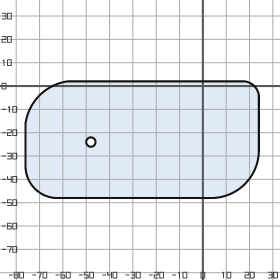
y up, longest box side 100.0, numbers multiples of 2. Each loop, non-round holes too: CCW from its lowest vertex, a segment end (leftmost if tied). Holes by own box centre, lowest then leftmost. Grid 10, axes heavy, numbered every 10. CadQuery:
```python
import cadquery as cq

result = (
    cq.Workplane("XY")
    .moveTo(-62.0, -48.0)
    .lineTo(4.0, -48.0)
    .threePointArc((18.0, -42.0), (24.0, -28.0))
    .lineTo(24.0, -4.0)
    .threePointArc((22.0, 0.0), (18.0, 2.0))
    .lineTo(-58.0, 2.0)
    .threePointArc((-70.0, -4.0), (-76.0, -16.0))
    .lineTo(-76.0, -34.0)
    .threePointArc((-72.0, -44.0), (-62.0, -48.0))
    .close()
    .moveTo(-48.0, -24.0)
    .circle(2.0)
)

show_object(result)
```